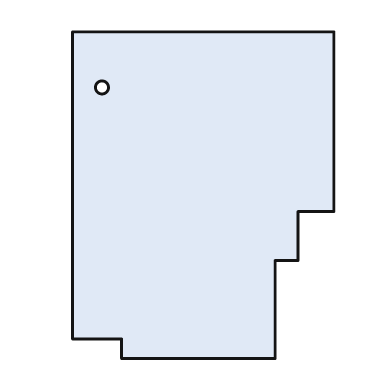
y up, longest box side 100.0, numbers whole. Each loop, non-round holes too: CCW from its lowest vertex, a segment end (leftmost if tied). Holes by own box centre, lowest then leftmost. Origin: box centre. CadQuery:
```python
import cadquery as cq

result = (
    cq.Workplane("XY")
    .moveTo(-25.0, -50.0)
    .lineTo(22.0, -50.0)
    .lineTo(22.0, -20.0)
    .lineTo(29.0, -20.0)
    .lineTo(29.0, -5.0)
    .lineTo(40.0, -5.0)
    .lineTo(40.0, 50.0)
    .lineTo(-40.0, 50.0)
    .lineTo(-40.0, -44.0)
    .lineTo(-25.0, -44.0)
    .close()
    .moveTo(-31.0, 33.0)
    .circle(2.0)
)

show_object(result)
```